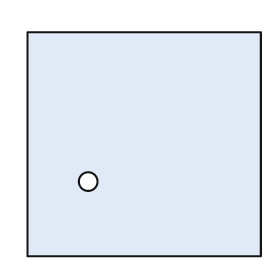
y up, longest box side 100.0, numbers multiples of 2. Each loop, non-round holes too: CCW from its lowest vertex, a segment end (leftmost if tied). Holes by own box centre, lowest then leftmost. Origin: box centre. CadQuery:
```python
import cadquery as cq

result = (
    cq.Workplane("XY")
    .moveTo(-50.0, -48.0)
    .lineTo(50.0, -48.0)
    .lineTo(50.0, 48.0)
    .lineTo(-50.0, 48.0)
    .close()
    .moveTo(-24.0, -16.0)
    .circle(4.0)
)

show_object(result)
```